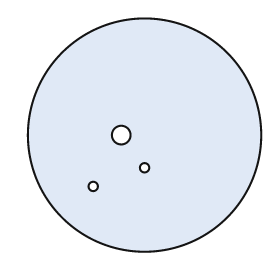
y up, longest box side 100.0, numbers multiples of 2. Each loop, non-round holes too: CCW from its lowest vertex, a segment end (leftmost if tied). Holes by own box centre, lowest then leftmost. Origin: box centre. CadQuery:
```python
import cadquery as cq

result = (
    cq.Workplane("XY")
    .moveTo(0.0, 0.0)
    .circle(50.0)
    .moveTo(-22.0, -22.0)
    .circle(2.0)
    .moveTo(0.0, -14.0)
    .circle(2.0)
    .moveTo(-10.0, 0.0)
    .circle(4.0)
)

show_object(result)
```